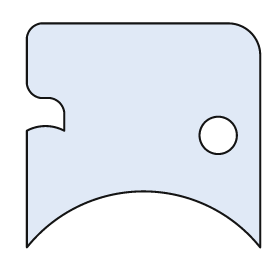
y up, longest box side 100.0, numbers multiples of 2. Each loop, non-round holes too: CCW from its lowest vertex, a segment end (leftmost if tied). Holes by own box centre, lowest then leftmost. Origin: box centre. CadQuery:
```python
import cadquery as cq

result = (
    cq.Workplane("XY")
    .moveTo(-50.0, -48.0)
    .threePointArc((0.0, -24.0), (50.0, -48.0))
    .lineTo(50.0, 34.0)
    .threePointArc((46.0, 44.0), (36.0, 48.0))
    .lineTo(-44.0, 48.0)
    .threePointArc((-48.0, 46.0), (-50.0, 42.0))
    .lineTo(-50.0, 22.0)
    .threePointArc((-48.0, 18.0), (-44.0, 16.0))
    .lineTo(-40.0, 16.0)
    .threePointArc((-36.0, 14.0), (-34.0, 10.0))
    .lineTo(-34.0, 2.0)
    .threePointArc((-42.0, 4.0), (-50.0, 2.0))
    .close()
    .moveTo(32.0, 0.0)
    .circle(8.0)
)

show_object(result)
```